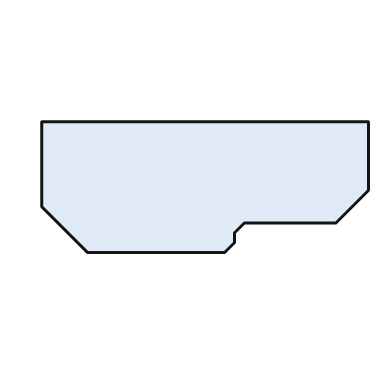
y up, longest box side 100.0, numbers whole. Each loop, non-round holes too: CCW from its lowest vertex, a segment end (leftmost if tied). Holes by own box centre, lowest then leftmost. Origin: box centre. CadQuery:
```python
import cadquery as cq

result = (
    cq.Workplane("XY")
    .moveTo(-36.0, -20.0)
    .lineTo(6.0, -20.0)
    .lineTo(9.0, -17.0)
    .lineTo(9.0, -14.0)
    .lineTo(12.0, -11.0)
    .lineTo(40.0, -11.0)
    .lineTo(50.0, -1.0)
    .lineTo(50.0, 20.0)
    .lineTo(-50.0, 20.0)
    .lineTo(-50.0, -6.0)
    .close()
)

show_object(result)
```